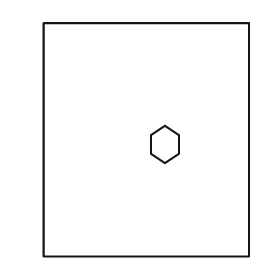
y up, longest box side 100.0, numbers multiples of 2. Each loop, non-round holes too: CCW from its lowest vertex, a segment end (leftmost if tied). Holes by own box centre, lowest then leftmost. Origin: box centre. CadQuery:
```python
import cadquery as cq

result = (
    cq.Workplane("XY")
    .moveTo(-44.0, -50.0)
    .lineTo(44.0, -50.0)
    .lineTo(44.0, 50.0)
    .lineTo(-44.0, 50.0)
    .close()
    .moveTo(8.0, -10.0)
    .lineTo(14.0, -6.0)
    .lineTo(14.0, 2.0)
    .lineTo(8.0, 6.0)
    .lineTo(2.0, 2.0)
    .lineTo(2.0, -6.0)
    .close()
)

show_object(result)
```